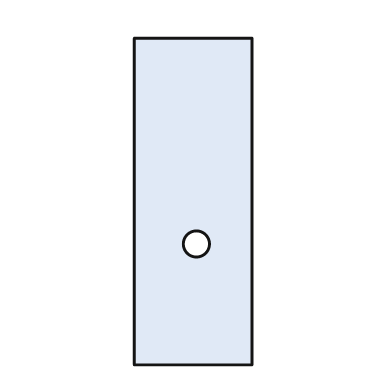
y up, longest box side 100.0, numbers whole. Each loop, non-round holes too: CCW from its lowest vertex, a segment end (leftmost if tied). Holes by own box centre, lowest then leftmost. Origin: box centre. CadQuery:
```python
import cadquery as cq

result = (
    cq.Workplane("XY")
    .moveTo(-18.0, -50.0)
    .lineTo(18.0, -50.0)
    .lineTo(18.0, 50.0)
    .lineTo(-18.0, 50.0)
    .close()
    .moveTo(1.0, -13.0)
    .circle(4.0)
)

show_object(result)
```